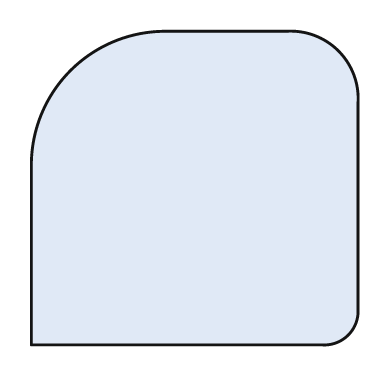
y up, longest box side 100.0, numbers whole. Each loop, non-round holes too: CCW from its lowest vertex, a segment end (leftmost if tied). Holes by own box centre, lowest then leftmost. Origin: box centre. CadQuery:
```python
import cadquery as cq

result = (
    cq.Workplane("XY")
    .moveTo(-50.0, -48.0)
    .lineTo(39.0, -48.0)
    .threePointArc((47.0, -45.0), (50.0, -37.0))
    .lineTo(50.0, 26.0)
    .threePointArc((44.0, 42.0), (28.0, 48.0))
    .lineTo(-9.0, 48.0)
    .threePointArc((-38.0, 36.0), (-50.0, 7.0))
    .close()
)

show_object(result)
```